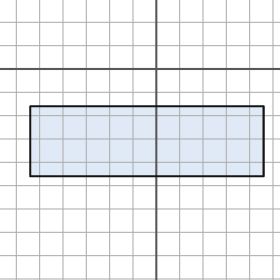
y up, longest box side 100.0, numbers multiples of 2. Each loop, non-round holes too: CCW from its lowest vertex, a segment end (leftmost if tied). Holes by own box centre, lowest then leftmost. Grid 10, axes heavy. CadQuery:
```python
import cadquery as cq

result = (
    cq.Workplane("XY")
    .moveTo(-54.0, -46.0)
    .lineTo(46.0, -46.0)
    .lineTo(46.0, -16.0)
    .lineTo(-54.0, -16.0)
    .close()
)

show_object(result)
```